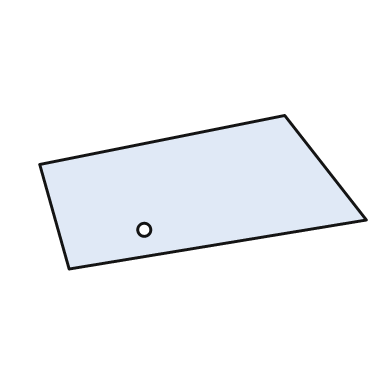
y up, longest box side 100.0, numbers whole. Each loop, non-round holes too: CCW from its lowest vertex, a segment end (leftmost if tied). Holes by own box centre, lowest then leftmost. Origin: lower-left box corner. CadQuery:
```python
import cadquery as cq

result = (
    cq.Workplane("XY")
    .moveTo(9.0, 0.0)
    .lineTo(100.0, 15.0)
    .lineTo(75.0, 47.0)
    .lineTo(0.0, 32.0)
    .close()
    .moveTo(32.0, 12.0)
    .circle(2.0)
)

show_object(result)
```